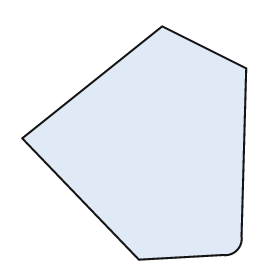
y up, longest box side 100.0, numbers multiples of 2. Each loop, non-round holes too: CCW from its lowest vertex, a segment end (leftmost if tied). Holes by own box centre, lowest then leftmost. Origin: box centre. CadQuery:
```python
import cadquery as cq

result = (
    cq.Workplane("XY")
    .moveTo(2.0, -50.0)
    .lineTo(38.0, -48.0)
    .threePointArc((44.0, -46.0), (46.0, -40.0))
    .lineTo(48.0, 32.0)
    .lineTo(12.0, 50.0)
    .lineTo(-48.0, 2.0)
    .close()
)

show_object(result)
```